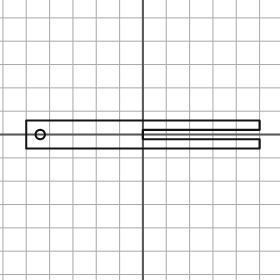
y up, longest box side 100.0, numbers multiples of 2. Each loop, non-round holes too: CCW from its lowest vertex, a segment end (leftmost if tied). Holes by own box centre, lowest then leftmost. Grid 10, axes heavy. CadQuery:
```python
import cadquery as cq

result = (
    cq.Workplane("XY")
    .moveTo(-50.0, -6.0)
    .lineTo(50.0, -6.0)
    .lineTo(50.0, -2.0)
    .lineTo(0.0, -2.0)
    .lineTo(0.0, 2.0)
    .lineTo(50.0, 2.0)
    .lineTo(50.0, 6.0)
    .lineTo(-50.0, 6.0)
    .close()
    .moveTo(-44.0, 0.0)
    .circle(2.0)
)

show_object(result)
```